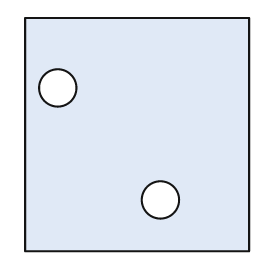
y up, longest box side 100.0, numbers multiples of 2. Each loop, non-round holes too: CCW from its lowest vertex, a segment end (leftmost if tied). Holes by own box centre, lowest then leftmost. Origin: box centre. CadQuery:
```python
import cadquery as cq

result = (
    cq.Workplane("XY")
    .moveTo(-48.0, -50.0)
    .lineTo(48.0, -50.0)
    .lineTo(48.0, 50.0)
    .lineTo(-48.0, 50.0)
    .close()
    .moveTo(10.0, -28.0)
    .circle(8.0)
    .moveTo(-34.0, 20.0)
    .circle(8.0)
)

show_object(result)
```